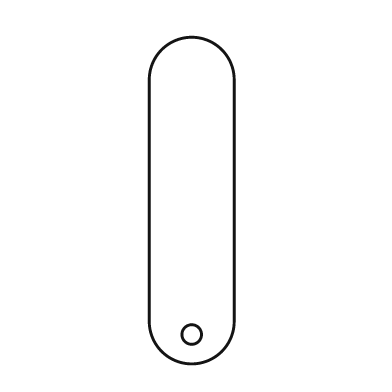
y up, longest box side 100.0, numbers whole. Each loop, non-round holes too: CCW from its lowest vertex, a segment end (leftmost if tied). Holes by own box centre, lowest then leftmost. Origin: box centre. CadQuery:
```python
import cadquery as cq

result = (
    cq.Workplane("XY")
    .moveTo(-13.0, -37.0)
    .threePointArc((0.0, -50.0), (13.0, -37.0))
    .lineTo(13.0, 37.0)
    .threePointArc((0.0, 50.0), (-13.0, 37.0))
    .close()
    .moveTo(0.0, -41.0)
    .circle(3.0)
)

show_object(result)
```